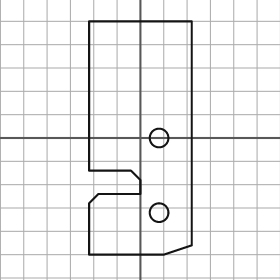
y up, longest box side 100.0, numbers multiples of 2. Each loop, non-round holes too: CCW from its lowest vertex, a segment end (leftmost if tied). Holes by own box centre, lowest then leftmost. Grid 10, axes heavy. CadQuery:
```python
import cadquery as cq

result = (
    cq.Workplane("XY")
    .moveTo(-22.0, -50.0)
    .lineTo(10.0, -50.0)
    .lineTo(22.0, -46.0)
    .lineTo(22.0, 50.0)
    .lineTo(-22.0, 50.0)
    .lineTo(-22.0, -14.0)
    .lineTo(-4.0, -14.0)
    .lineTo(0.0, -18.0)
    .lineTo(0.0, -24.0)
    .lineTo(-18.0, -24.0)
    .lineTo(-22.0, -28.0)
    .close()
    .moveTo(8.0, -32.0)
    .circle(4.0)
    .moveTo(8.0, 0.0)
    .circle(4.0)
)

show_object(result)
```